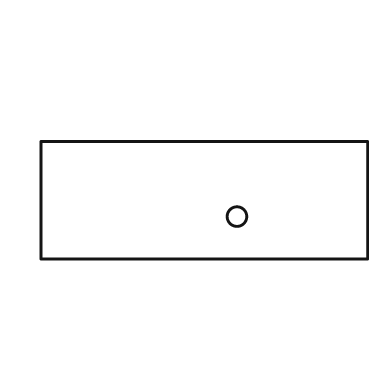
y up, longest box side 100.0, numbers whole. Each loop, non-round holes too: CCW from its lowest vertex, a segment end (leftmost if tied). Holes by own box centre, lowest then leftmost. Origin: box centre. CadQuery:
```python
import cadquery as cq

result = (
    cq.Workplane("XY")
    .moveTo(-50.0, -18.0)
    .lineTo(50.0, -18.0)
    .lineTo(50.0, 18.0)
    .lineTo(-50.0, 18.0)
    .close()
    .moveTo(10.0, -5.0)
    .circle(3.0)
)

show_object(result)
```